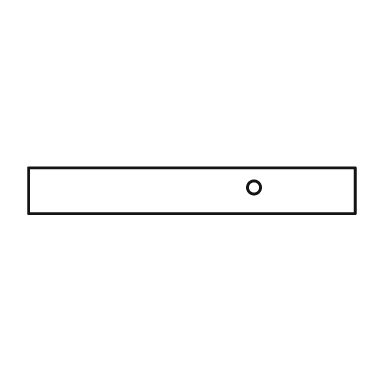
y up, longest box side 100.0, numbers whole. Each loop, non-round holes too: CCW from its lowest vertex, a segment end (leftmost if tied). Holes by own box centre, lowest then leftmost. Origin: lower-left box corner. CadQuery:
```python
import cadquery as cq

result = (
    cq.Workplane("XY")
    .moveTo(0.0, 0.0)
    .lineTo(100.0, 0.0)
    .lineTo(100.0, 14.0)
    .lineTo(0.0, 14.0)
    .close()
    .moveTo(69.0, 8.0)
    .circle(2.0)
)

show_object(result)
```